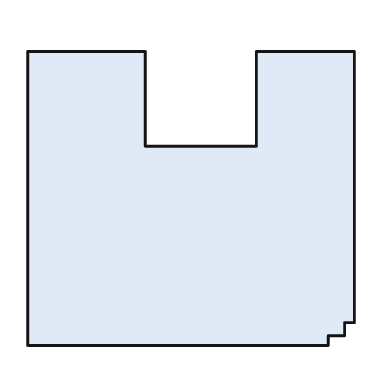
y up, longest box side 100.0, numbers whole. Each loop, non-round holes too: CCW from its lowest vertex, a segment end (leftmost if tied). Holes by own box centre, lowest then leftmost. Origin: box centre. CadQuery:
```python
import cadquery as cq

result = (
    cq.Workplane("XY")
    .moveTo(-50.0, -45.0)
    .lineTo(42.0, -45.0)
    .lineTo(42.0, -42.0)
    .lineTo(47.0, -42.0)
    .lineTo(47.0, -38.0)
    .lineTo(50.0, -38.0)
    .lineTo(50.0, 45.0)
    .lineTo(20.0, 45.0)
    .lineTo(20.0, 16.0)
    .lineTo(-14.0, 16.0)
    .lineTo(-14.0, 45.0)
    .lineTo(-50.0, 45.0)
    .close()
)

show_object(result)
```